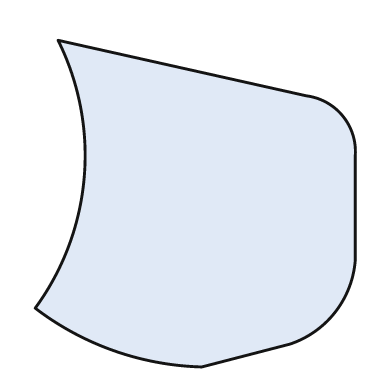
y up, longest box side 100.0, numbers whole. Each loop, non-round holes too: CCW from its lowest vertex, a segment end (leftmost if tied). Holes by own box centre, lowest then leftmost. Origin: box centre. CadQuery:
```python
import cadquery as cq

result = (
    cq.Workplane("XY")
    .moveTo(2.0, -50.0)
    .lineTo(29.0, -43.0)
    .threePointArc((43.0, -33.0), (49.0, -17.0))
    .lineTo(49.0, 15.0)
    .threePointArc((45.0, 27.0), (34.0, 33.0))
    .lineTo(-42.0, 50.0)
    .threePointArc((-34.0, 8.0), (-49.0, -32.0))
    .threePointArc((-25.0, -45.0), (2.0, -50.0))
    .close()
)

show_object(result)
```